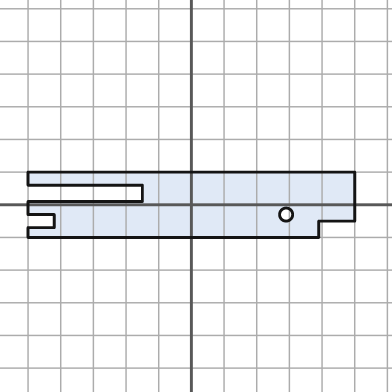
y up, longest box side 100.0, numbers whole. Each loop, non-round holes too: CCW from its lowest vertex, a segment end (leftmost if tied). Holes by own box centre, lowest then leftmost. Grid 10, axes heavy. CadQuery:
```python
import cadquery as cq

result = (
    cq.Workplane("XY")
    .moveTo(-50.0, -10.0)
    .lineTo(39.0, -10.0)
    .lineTo(39.0, -5.0)
    .lineTo(50.0, -5.0)
    .lineTo(50.0, 10.0)
    .lineTo(-50.0, 10.0)
    .lineTo(-50.0, 6.0)
    .lineTo(-15.0, 6.0)
    .lineTo(-15.0, 1.0)
    .lineTo(-50.0, 1.0)
    .lineTo(-50.0, -3.0)
    .lineTo(-42.0, -3.0)
    .lineTo(-42.0, -7.0)
    .lineTo(-50.0, -7.0)
    .close()
    .moveTo(29.0, -3.0)
    .circle(2.0)
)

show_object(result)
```